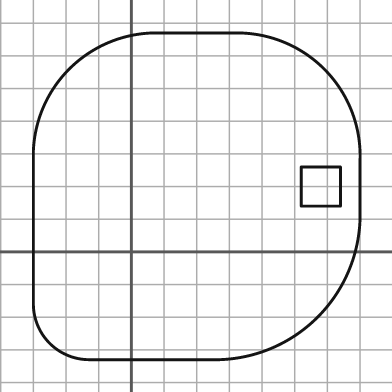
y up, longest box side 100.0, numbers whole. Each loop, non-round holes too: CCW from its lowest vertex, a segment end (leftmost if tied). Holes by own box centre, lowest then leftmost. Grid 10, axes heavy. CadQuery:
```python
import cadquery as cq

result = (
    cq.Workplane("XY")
    .moveTo(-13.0, -33.0)
    .lineTo(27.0, -33.0)
    .threePointArc((57.0, -20.0), (70.0, 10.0))
    .lineTo(70.0, 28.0)
    .threePointArc((59.0, 56.0), (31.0, 67.0))
    .lineTo(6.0, 67.0)
    .threePointArc((-19.0, 56.0), (-30.0, 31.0))
    .lineTo(-30.0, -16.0)
    .threePointArc((-25.0, -28.0), (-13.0, -33.0))
    .close()
    .moveTo(52.0, 14.0)
    .lineTo(64.0, 14.0)
    .lineTo(64.0, 26.0)
    .lineTo(52.0, 26.0)
    .close()
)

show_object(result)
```